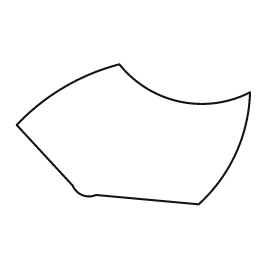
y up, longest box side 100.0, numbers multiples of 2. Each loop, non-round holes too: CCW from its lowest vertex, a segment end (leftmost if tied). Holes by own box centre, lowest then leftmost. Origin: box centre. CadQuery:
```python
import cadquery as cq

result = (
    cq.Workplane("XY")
    .moveTo(28.0, -30.0)
    .threePointArc((44.0, -8.0), (50.0, 18.0))
    .threePointArc((20.0, 14.0), (-6.0, 30.0))
    .threePointArc((-30.0, 20.0), (-50.0, 4.0))
    .lineTo(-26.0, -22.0)
    .threePointArc((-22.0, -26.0), (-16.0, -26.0))
    .close()
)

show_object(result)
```